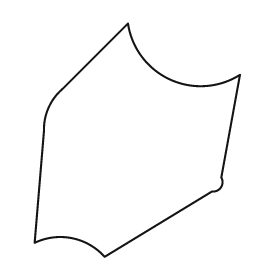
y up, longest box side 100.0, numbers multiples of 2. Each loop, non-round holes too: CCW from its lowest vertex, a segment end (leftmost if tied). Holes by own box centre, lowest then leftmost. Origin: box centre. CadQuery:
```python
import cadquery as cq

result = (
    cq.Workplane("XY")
    .moveTo(-14.0, -50.0)
    .lineTo(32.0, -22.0)
    .threePointArc((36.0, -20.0), (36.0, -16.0))
    .lineTo(44.0, 28.0)
    .threePointArc((14.0, 26.0), (-4.0, 50.0))
    .lineTo(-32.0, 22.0)
    .threePointArc((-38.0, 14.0), (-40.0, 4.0))
    .lineTo(-44.0, -44.0)
    .threePointArc((-28.0, -42.0), (-14.0, -50.0))
    .close()
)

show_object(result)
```